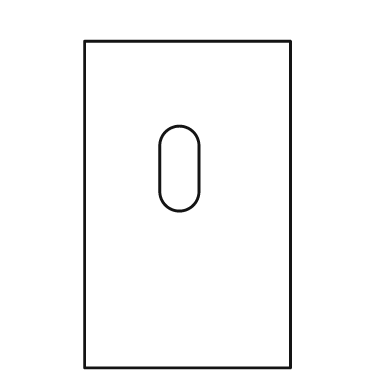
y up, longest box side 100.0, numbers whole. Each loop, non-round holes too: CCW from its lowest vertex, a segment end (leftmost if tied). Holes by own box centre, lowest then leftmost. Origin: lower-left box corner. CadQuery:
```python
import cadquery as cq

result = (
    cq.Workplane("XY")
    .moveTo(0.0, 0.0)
    .lineTo(63.0, 0.0)
    .lineTo(63.0, 100.0)
    .lineTo(0.0, 100.0)
    .close()
    .moveTo(23.0, 54.0)
    .threePointArc((29.0, 48.0), (35.0, 54.0))
    .lineTo(35.0, 68.0)
    .threePointArc((29.0, 74.0), (23.0, 68.0))
    .close()
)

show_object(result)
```